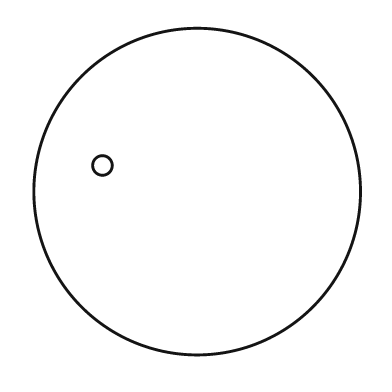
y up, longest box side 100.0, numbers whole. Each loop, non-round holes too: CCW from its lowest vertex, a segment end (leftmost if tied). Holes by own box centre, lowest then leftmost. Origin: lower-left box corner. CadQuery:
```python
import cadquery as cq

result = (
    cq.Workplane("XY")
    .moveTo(50.0, 50.0)
    .circle(50.0)
    .moveTo(21.0, 58.0)
    .circle(3.0)
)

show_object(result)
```